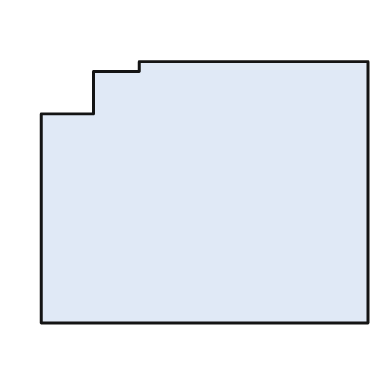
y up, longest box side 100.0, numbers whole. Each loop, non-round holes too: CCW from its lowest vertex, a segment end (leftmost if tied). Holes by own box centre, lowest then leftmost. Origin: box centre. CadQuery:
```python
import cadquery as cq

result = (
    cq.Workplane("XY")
    .moveTo(-50.0, -40.0)
    .lineTo(50.0, -40.0)
    .lineTo(50.0, 40.0)
    .lineTo(-20.0, 40.0)
    .lineTo(-20.0, 37.0)
    .lineTo(-34.0, 37.0)
    .lineTo(-34.0, 24.0)
    .lineTo(-50.0, 24.0)
    .close()
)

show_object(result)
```